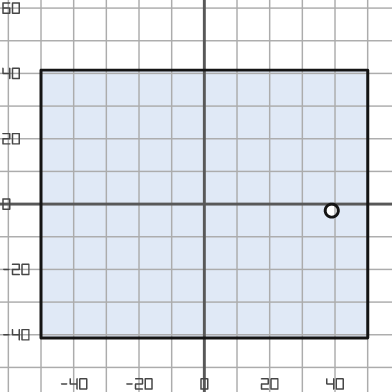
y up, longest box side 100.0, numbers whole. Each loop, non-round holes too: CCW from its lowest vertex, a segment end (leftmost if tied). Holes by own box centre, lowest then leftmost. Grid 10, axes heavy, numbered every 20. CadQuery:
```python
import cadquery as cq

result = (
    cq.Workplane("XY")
    .moveTo(-50.0, -41.0)
    .lineTo(50.0, -41.0)
    .lineTo(50.0, 41.0)
    .lineTo(-50.0, 41.0)
    .close()
    .moveTo(39.0, -2.0)
    .circle(2.0)
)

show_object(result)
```